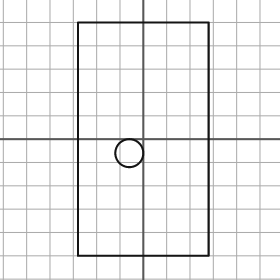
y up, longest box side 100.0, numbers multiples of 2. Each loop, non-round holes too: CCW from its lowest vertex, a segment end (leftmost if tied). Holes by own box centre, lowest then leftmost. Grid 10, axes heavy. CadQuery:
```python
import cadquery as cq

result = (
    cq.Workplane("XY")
    .moveTo(-28.0, -50.0)
    .lineTo(28.0, -50.0)
    .lineTo(28.0, 50.0)
    .lineTo(-28.0, 50.0)
    .close()
    .moveTo(-6.0, -6.0)
    .circle(6.0)
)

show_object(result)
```